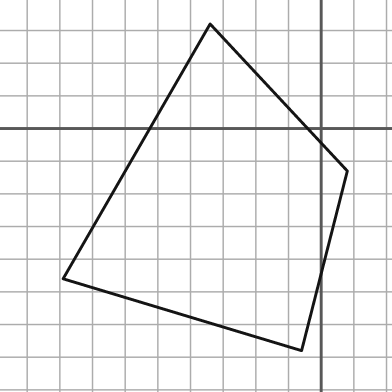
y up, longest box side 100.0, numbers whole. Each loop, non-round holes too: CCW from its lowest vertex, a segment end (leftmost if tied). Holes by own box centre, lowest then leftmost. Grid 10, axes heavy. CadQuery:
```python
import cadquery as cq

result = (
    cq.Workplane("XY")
    .moveTo(-6.0, -68.0)
    .lineTo(8.0, -13.0)
    .lineTo(-34.0, 32.0)
    .lineTo(-79.0, -46.0)
    .close()
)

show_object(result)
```